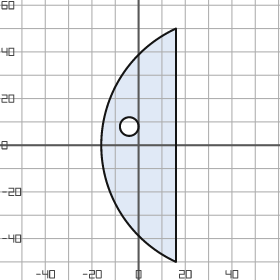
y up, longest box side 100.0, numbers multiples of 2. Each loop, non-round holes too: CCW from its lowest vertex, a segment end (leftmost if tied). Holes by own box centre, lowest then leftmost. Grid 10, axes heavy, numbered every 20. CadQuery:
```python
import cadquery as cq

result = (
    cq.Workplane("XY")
    .moveTo(16.0, -50.0)
    .lineTo(16.0, 50.0)
    .threePointArc((-16.0, 0.0), (16.0, -50.0))
    .close()
    .moveTo(-4.0, 8.0)
    .circle(4.0)
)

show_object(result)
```